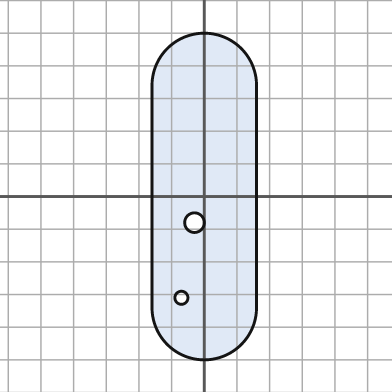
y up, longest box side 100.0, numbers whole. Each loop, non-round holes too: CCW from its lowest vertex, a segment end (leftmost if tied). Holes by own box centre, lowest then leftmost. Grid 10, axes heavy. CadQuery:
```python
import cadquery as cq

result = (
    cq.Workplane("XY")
    .moveTo(-16.0, -34.0)
    .threePointArc((0.0, -50.0), (16.0, -34.0))
    .lineTo(16.0, 34.0)
    .threePointArc((0.0, 50.0), (-16.0, 34.0))
    .close()
    .moveTo(-7.0, -31.0)
    .circle(2.0)
    .moveTo(-3.0, -8.0)
    .circle(3.0)
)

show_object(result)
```